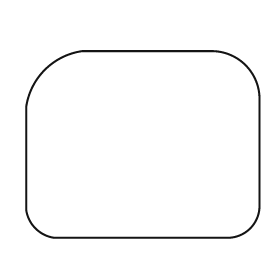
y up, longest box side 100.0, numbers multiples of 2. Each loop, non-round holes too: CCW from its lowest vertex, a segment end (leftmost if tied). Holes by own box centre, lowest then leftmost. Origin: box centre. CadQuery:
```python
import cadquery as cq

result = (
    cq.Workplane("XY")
    .moveTo(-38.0, -40.0)
    .lineTo(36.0, -40.0)
    .threePointArc((46.0, -36.0), (50.0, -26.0))
    .lineTo(50.0, 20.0)
    .threePointArc((44.0, 34.0), (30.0, 40.0))
    .lineTo(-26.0, 40.0)
    .threePointArc((-42.0, 32.0), (-50.0, 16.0))
    .lineTo(-50.0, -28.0)
    .threePointArc((-46.0, -36.0), (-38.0, -40.0))
    .close()
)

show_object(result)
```